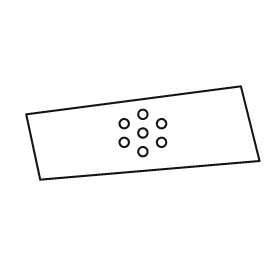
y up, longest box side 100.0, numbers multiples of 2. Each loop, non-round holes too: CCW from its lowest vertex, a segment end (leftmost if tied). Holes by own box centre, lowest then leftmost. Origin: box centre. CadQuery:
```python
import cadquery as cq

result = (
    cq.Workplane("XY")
    .moveTo(-44.0, -20.0)
    .lineTo(50.0, -12.0)
    .lineTo(42.0, 20.0)
    .lineTo(-50.0, 8.0)
    .close()
    .moveTo(0.0, -8.0)
    .circle(2.0)
    .moveTo(-8.0, -4.0)
    .circle(2.0)
    .moveTo(8.0, -4.0)
    .circle(2.0)
    .moveTo(0.0, 0.0)
    .circle(2.0)
    .moveTo(-8.0, 4.0)
    .circle(2.0)
    .moveTo(8.0, 4.0)
    .circle(2.0)
    .moveTo(0.0, 8.0)
    .circle(2.0)
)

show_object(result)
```